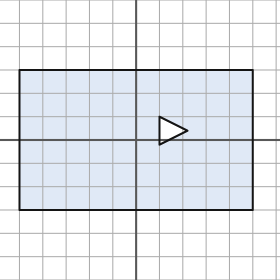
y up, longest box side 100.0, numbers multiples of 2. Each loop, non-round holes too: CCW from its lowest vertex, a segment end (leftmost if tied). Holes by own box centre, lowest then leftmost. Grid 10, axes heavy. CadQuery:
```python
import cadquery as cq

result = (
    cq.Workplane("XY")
    .moveTo(-50.0, -30.0)
    .lineTo(50.0, -30.0)
    .lineTo(50.0, 30.0)
    .lineTo(-50.0, 30.0)
    .close()
    .moveTo(10.0, -2.0)
    .lineTo(22.0, 4.0)
    .lineTo(10.0, 10.0)
    .close()
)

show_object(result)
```